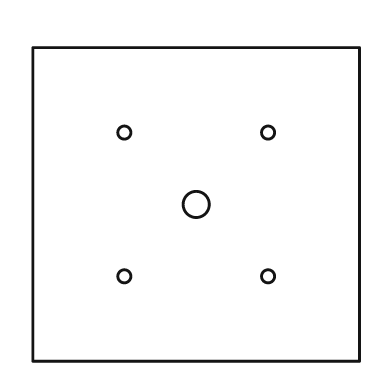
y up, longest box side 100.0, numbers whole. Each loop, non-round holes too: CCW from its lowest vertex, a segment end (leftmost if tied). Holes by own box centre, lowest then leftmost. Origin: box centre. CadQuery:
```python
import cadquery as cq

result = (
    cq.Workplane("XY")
    .moveTo(-50.0, -48.0)
    .lineTo(50.0, -48.0)
    .lineTo(50.0, 48.0)
    .lineTo(-50.0, 48.0)
    .close()
    .moveTo(-22.0, -22.0)
    .circle(2.0)
    .moveTo(22.0, -22.0)
    .circle(2.0)
    .moveTo(0.0, 0.0)
    .circle(4.0)
    .moveTo(-22.0, 22.0)
    .circle(2.0)
    .moveTo(22.0, 22.0)
    .circle(2.0)
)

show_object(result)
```